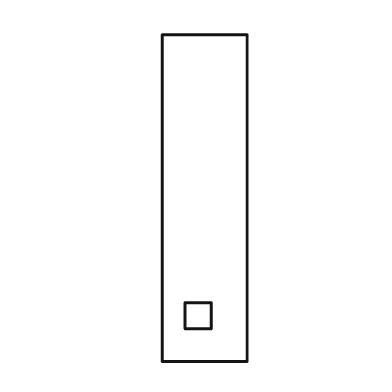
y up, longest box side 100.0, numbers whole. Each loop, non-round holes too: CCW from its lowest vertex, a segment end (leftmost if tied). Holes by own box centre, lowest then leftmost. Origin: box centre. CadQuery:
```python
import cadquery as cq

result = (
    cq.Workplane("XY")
    .moveTo(-13.0, -50.0)
    .lineTo(13.0, -50.0)
    .lineTo(13.0, 50.0)
    .lineTo(-13.0, 50.0)
    .close()
    .moveTo(-6.0, -40.0)
    .lineTo(2.0, -40.0)
    .lineTo(2.0, -32.0)
    .lineTo(-6.0, -32.0)
    .close()
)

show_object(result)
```